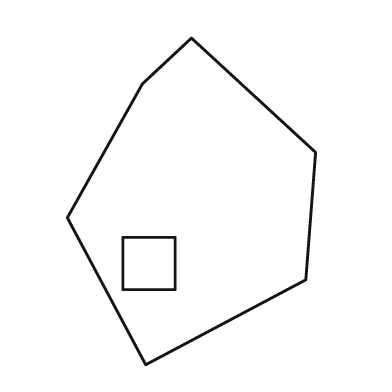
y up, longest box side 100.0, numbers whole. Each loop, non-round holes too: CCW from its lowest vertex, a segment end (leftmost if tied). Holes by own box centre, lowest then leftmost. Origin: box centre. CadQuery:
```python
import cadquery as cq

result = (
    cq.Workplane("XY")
    .moveTo(-14.0, -50.0)
    .lineTo(35.0, -24.0)
    .lineTo(38.0, 15.0)
    .lineTo(0.0, 50.0)
    .lineTo(-15.0, 36.0)
    .lineTo(-38.0, -5.0)
    .close()
    .moveTo(-21.0, -27.0)
    .lineTo(-5.0, -27.0)
    .lineTo(-5.0, -11.0)
    .lineTo(-21.0, -11.0)
    .close()
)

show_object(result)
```